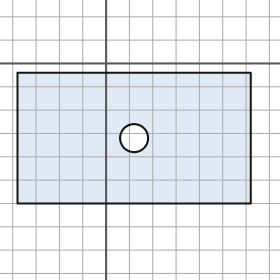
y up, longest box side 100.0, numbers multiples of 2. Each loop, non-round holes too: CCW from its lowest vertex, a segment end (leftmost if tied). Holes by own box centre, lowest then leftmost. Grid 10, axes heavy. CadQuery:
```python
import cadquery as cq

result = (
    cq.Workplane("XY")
    .moveTo(-38.0, -60.0)
    .lineTo(62.0, -60.0)
    .lineTo(62.0, -4.0)
    .lineTo(-38.0, -4.0)
    .close()
    .moveTo(12.0, -32.0)
    .circle(6.0)
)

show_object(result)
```